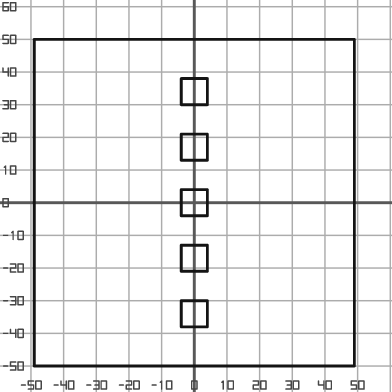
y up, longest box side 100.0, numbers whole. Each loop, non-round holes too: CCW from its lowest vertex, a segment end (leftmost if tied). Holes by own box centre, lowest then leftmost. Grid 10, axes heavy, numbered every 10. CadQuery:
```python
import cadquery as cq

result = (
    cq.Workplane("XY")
    .moveTo(-49.0, -50.0)
    .lineTo(49.0, -50.0)
    .lineTo(49.0, 50.0)
    .lineTo(-49.0, 50.0)
    .close()
    .moveTo(-4.0, -38.0)
    .lineTo(4.0, -38.0)
    .lineTo(4.0, -30.0)
    .lineTo(-4.0, -30.0)
    .close()
    .moveTo(-4.0, -21.0)
    .lineTo(4.0, -21.0)
    .lineTo(4.0, -13.0)
    .lineTo(-4.0, -13.0)
    .close()
    .moveTo(-4.0, -4.0)
    .lineTo(4.0, -4.0)
    .lineTo(4.0, 4.0)
    .lineTo(-4.0, 4.0)
    .close()
    .moveTo(-4.0, 13.0)
    .lineTo(4.0, 13.0)
    .lineTo(4.0, 21.0)
    .lineTo(-4.0, 21.0)
    .close()
    .moveTo(-4.0, 30.0)
    .lineTo(4.0, 30.0)
    .lineTo(4.0, 38.0)
    .lineTo(-4.0, 38.0)
    .close()
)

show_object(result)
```